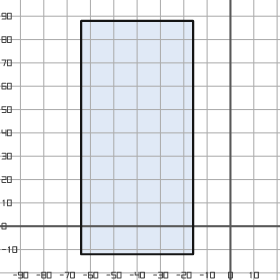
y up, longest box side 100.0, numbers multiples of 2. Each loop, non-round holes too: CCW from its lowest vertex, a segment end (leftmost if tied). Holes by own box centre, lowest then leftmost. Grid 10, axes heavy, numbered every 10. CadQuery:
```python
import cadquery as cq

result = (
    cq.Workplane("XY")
    .moveTo(-64.0, -12.0)
    .lineTo(-16.0, -12.0)
    .lineTo(-16.0, 88.0)
    .lineTo(-64.0, 88.0)
    .close()
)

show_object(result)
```